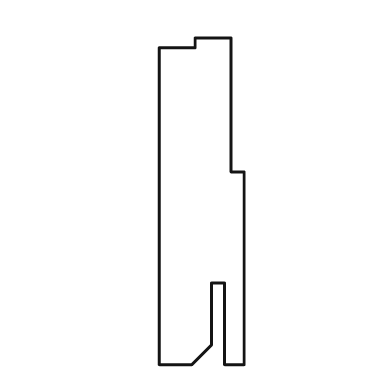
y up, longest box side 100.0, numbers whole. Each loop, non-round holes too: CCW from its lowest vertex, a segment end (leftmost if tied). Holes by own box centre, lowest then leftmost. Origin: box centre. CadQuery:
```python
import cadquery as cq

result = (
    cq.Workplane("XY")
    .moveTo(-13.0, -50.0)
    .lineTo(-3.0, -50.0)
    .lineTo(3.0, -44.0)
    .lineTo(3.0, -25.0)
    .lineTo(7.0, -25.0)
    .lineTo(7.0, -50.0)
    .lineTo(13.0, -50.0)
    .lineTo(13.0, 9.0)
    .lineTo(9.0, 9.0)
    .lineTo(9.0, 50.0)
    .lineTo(-2.0, 50.0)
    .lineTo(-2.0, 47.0)
    .lineTo(-13.0, 47.0)
    .close()
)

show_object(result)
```